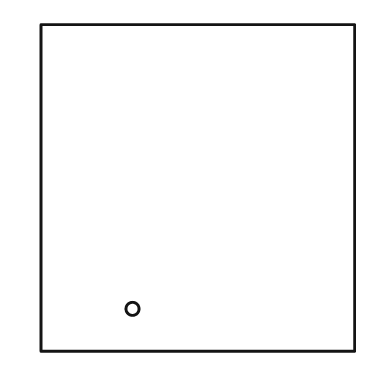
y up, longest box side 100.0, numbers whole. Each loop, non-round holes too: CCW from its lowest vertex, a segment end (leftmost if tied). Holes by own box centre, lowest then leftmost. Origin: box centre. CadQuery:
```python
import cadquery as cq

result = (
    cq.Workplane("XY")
    .moveTo(-48.0, -50.0)
    .lineTo(48.0, -50.0)
    .lineTo(48.0, 50.0)
    .lineTo(-48.0, 50.0)
    .close()
    .moveTo(-20.0, -37.0)
    .circle(2.0)
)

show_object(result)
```